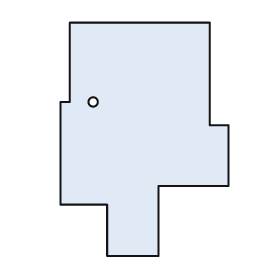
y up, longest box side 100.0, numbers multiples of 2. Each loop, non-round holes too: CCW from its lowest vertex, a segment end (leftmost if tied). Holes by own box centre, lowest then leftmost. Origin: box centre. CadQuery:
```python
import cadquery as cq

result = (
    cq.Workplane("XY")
    .moveTo(-16.0, -50.0)
    .lineTo(6.0, -50.0)
    .lineTo(6.0, -20.0)
    .lineTo(36.0, -20.0)
    .lineTo(36.0, 6.0)
    .lineTo(28.0, 6.0)
    .lineTo(28.0, 50.0)
    .lineTo(-32.0, 50.0)
    .lineTo(-32.0, 16.0)
    .lineTo(-36.0, 16.0)
    .lineTo(-36.0, -28.0)
    .lineTo(-16.0, -28.0)
    .close()
    .moveTo(-22.0, 16.0)
    .circle(2.0)
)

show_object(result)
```